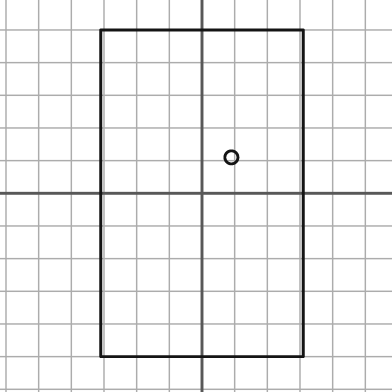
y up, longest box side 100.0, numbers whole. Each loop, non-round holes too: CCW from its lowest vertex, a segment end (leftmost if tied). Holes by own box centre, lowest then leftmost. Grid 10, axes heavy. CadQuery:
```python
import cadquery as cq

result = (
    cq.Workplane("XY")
    .moveTo(-31.0, -50.0)
    .lineTo(31.0, -50.0)
    .lineTo(31.0, 50.0)
    .lineTo(-31.0, 50.0)
    .close()
    .moveTo(9.0, 11.0)
    .circle(2.0)
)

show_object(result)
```